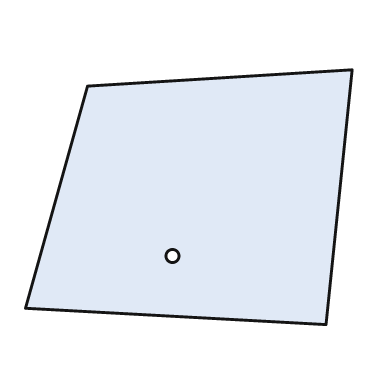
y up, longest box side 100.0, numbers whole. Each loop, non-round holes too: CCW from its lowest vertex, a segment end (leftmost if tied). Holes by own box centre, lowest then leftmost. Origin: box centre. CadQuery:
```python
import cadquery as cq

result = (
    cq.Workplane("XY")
    .moveTo(42.0, -39.0)
    .lineTo(50.0, 39.0)
    .lineTo(-31.0, 34.0)
    .lineTo(-50.0, -34.0)
    .close()
    .moveTo(-5.0, -18.0)
    .circle(2.0)
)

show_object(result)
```